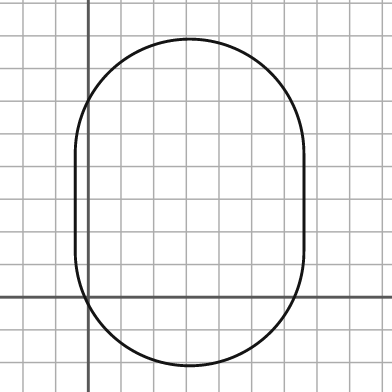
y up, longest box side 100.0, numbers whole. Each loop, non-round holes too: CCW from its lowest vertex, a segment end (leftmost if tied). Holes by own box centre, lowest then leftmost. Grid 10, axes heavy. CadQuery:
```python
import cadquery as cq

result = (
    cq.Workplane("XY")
    .moveTo(-4.0, 14.0)
    .threePointArc((31.0, -21.0), (66.0, 14.0))
    .lineTo(66.0, 44.0)
    .threePointArc((31.0, 79.0), (-4.0, 44.0))
    .close()
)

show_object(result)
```